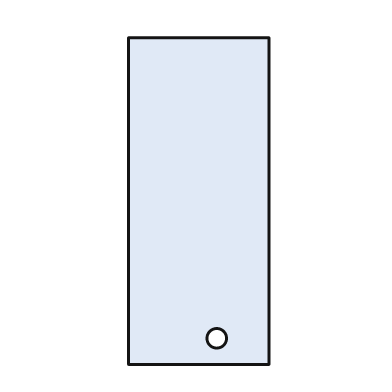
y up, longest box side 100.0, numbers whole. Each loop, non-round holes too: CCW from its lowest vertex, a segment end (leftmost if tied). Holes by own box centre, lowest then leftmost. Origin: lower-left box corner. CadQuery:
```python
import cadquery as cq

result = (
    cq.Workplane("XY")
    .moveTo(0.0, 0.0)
    .lineTo(43.0, 0.0)
    .lineTo(43.0, 100.0)
    .lineTo(0.0, 100.0)
    .close()
    .moveTo(27.0, 8.0)
    .circle(3.0)
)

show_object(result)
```